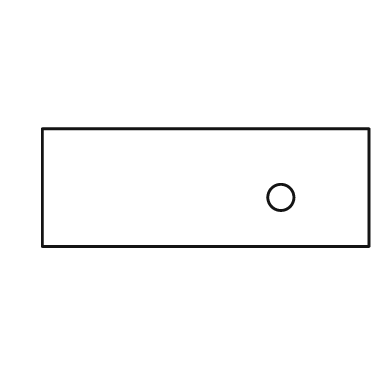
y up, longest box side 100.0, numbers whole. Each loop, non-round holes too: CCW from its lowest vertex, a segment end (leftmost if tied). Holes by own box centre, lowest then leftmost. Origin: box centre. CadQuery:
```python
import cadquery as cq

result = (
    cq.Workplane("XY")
    .moveTo(-50.0, -18.0)
    .lineTo(50.0, -18.0)
    .lineTo(50.0, 18.0)
    .lineTo(-50.0, 18.0)
    .close()
    .moveTo(23.0, -3.0)
    .circle(4.0)
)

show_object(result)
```